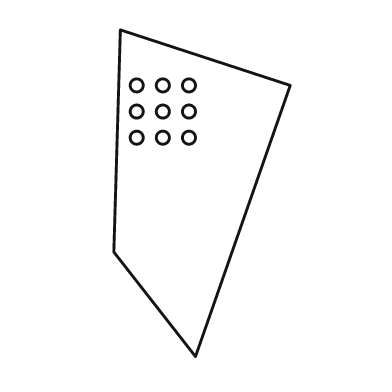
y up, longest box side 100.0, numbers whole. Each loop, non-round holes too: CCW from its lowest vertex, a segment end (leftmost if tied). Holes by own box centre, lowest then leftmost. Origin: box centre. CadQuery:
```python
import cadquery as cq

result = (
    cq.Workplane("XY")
    .moveTo(-2.0, -50.0)
    .lineTo(27.0, 33.0)
    .lineTo(-25.0, 50.0)
    .lineTo(-27.0, -18.0)
    .close()
    .moveTo(-20.0, 17.0)
    .circle(2.0)
    .moveTo(-12.0, 17.0)
    .circle(2.0)
    .moveTo(-4.0, 17.0)
    .circle(2.0)
    .moveTo(-20.0, 25.0)
    .circle(2.0)
    .moveTo(-12.0, 25.0)
    .circle(2.0)
    .moveTo(-4.0, 25.0)
    .circle(2.0)
    .moveTo(-20.0, 33.0)
    .circle(2.0)
    .moveTo(-12.0, 33.0)
    .circle(2.0)
    .moveTo(-4.0, 33.0)
    .circle(2.0)
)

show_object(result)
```